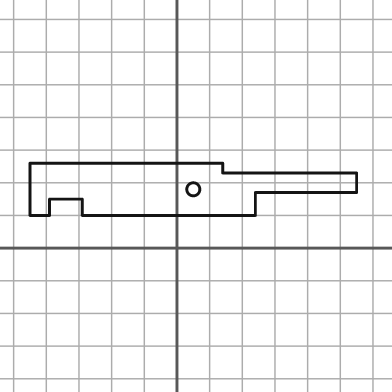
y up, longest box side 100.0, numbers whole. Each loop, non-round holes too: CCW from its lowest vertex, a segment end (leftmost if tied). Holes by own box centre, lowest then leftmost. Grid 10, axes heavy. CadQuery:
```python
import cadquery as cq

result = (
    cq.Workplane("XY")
    .moveTo(-45.0, 10.0)
    .lineTo(-39.0, 10.0)
    .lineTo(-39.0, 15.0)
    .lineTo(-29.0, 15.0)
    .lineTo(-29.0, 10.0)
    .lineTo(24.0, 10.0)
    .lineTo(24.0, 17.0)
    .lineTo(55.0, 17.0)
    .lineTo(55.0, 23.0)
    .lineTo(14.0, 23.0)
    .lineTo(14.0, 26.0)
    .lineTo(-45.0, 26.0)
    .close()
    .moveTo(5.0, 18.0)
    .circle(2.0)
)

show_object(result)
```